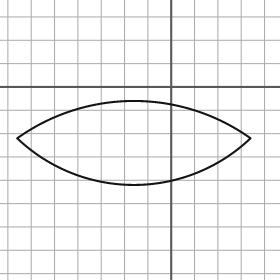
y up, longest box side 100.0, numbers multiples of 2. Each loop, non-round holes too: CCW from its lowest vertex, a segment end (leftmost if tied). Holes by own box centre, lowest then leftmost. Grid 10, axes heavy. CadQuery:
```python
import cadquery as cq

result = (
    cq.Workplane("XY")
    .moveTo(-66.0, -22.0)
    .threePointArc((-16.0, -42.0), (34.0, -22.0))
    .threePointArc((-16.0, -6.0), (-66.0, -22.0))
    .close()
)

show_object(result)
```